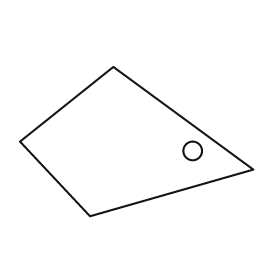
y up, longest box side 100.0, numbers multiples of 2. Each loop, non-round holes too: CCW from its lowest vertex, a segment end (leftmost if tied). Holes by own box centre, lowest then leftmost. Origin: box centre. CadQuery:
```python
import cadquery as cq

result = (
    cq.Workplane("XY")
    .moveTo(-20.0, -32.0)
    .lineTo(50.0, -12.0)
    .lineTo(-10.0, 32.0)
    .lineTo(-50.0, 0.0)
    .close()
    .moveTo(24.0, -4.0)
    .circle(4.0)
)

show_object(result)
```